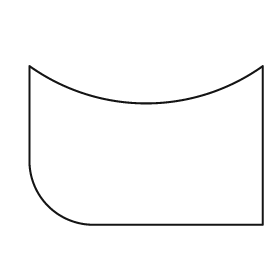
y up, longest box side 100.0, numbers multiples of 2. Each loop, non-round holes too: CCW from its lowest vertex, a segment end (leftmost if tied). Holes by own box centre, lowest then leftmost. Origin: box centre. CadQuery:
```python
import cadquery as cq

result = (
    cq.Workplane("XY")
    .moveTo(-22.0, -34.0)
    .lineTo(50.0, -34.0)
    .lineTo(50.0, 34.0)
    .threePointArc((0.0, 18.0), (-50.0, 34.0))
    .lineTo(-50.0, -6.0)
    .threePointArc((-42.0, -26.0), (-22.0, -34.0))
    .close()
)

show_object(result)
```